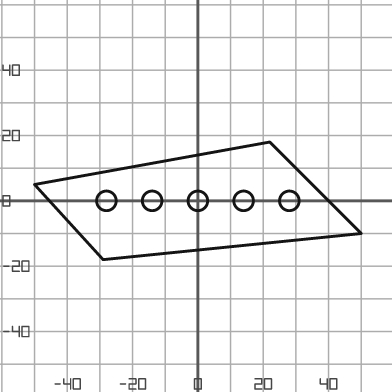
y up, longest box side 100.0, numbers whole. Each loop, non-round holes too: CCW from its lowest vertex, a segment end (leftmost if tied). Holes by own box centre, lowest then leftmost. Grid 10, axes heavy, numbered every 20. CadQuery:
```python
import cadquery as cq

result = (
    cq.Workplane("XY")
    .moveTo(-29.0, -18.0)
    .lineTo(50.0, -10.0)
    .lineTo(22.0, 18.0)
    .lineTo(-50.0, 5.0)
    .close()
    .moveTo(-28.0, 0.0)
    .circle(3.0)
    .moveTo(-14.0, 0.0)
    .circle(3.0)
    .moveTo(0.0, 0.0)
    .circle(3.0)
    .moveTo(14.0, 0.0)
    .circle(3.0)
    .moveTo(28.0, 0.0)
    .circle(3.0)
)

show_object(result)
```